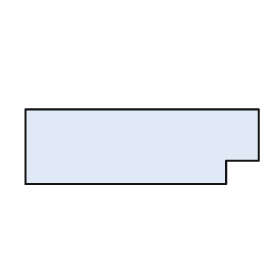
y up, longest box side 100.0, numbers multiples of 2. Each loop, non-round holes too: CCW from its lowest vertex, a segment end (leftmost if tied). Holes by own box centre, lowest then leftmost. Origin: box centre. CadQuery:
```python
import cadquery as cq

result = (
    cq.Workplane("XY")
    .moveTo(-50.0, -16.0)
    .lineTo(36.0, -16.0)
    .lineTo(36.0, -6.0)
    .lineTo(50.0, -6.0)
    .lineTo(50.0, 16.0)
    .lineTo(-50.0, 16.0)
    .close()
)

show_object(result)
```